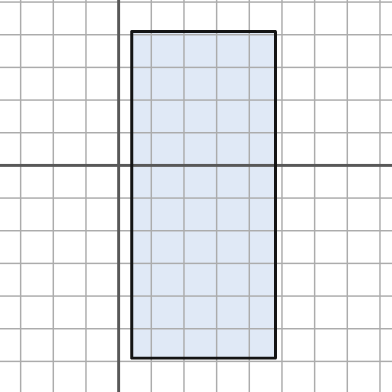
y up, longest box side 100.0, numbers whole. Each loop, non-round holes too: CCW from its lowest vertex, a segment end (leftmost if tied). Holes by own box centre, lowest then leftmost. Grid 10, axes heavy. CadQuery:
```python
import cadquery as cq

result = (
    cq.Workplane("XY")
    .moveTo(4.0, -59.0)
    .lineTo(48.0, -59.0)
    .lineTo(48.0, 41.0)
    .lineTo(4.0, 41.0)
    .close()
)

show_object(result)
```